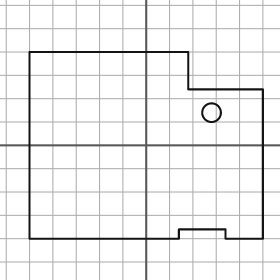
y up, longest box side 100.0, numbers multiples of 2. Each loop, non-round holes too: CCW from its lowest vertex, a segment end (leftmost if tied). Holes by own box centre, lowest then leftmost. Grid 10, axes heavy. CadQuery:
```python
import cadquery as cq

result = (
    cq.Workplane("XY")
    .moveTo(-50.0, -40.0)
    .lineTo(14.0, -40.0)
    .lineTo(14.0, -36.0)
    .lineTo(34.0, -36.0)
    .lineTo(34.0, -40.0)
    .lineTo(50.0, -40.0)
    .lineTo(50.0, 24.0)
    .lineTo(18.0, 24.0)
    .lineTo(18.0, 40.0)
    .lineTo(-50.0, 40.0)
    .close()
    .moveTo(28.0, 14.0)
    .circle(4.0)
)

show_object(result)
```